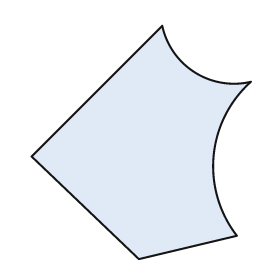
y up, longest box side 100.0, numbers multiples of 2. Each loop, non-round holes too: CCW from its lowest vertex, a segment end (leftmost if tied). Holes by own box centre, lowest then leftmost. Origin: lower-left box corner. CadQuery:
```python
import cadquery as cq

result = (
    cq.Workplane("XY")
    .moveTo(46.0, 0.0)
    .lineTo(88.0, 10.0)
    .threePointArc((78.0, 44.0), (94.0, 76.0))
    .threePointArc((70.0, 80.0), (56.0, 100.0))
    .lineTo(0.0, 44.0)
    .close()
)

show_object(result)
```